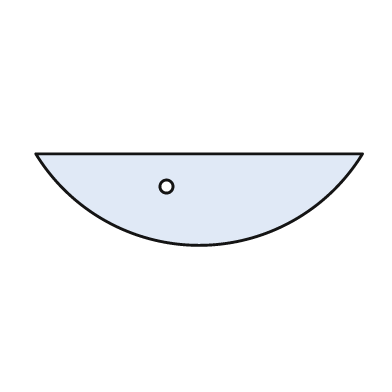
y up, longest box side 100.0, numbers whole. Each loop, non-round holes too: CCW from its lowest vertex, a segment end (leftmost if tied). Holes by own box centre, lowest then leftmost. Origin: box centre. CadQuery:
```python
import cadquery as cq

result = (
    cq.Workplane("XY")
    .moveTo(-50.0, 14.0)
    .threePointArc((0.0, -14.0), (50.0, 14.0))
    .close()
    .moveTo(-10.0, 4.0)
    .circle(2.0)
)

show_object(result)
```